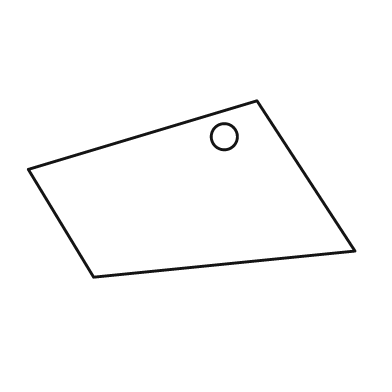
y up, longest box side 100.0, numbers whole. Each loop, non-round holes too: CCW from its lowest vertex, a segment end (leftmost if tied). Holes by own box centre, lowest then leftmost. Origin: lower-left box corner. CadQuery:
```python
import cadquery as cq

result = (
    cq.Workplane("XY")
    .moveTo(20.0, 0.0)
    .lineTo(100.0, 8.0)
    .lineTo(70.0, 54.0)
    .lineTo(0.0, 33.0)
    .close()
    .moveTo(60.0, 43.0)
    .circle(4.0)
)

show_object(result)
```